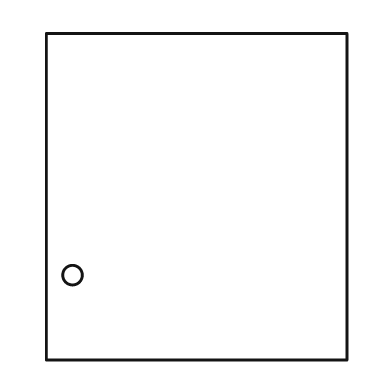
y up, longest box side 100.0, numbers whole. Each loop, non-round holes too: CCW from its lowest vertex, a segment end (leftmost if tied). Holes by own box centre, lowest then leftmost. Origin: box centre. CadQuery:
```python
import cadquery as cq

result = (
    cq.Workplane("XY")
    .moveTo(-46.0, -50.0)
    .lineTo(46.0, -50.0)
    .lineTo(46.0, 50.0)
    .lineTo(-46.0, 50.0)
    .close()
    .moveTo(-38.0, -24.0)
    .circle(3.0)
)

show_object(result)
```